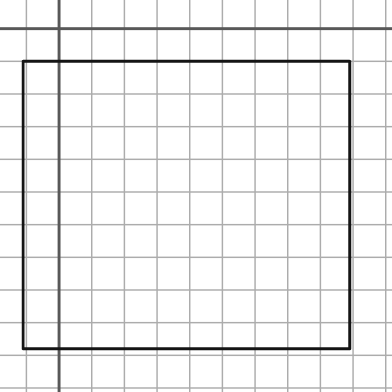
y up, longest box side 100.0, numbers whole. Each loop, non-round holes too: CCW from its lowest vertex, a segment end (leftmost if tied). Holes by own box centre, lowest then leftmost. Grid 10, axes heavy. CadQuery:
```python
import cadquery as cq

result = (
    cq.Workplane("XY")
    .moveTo(-11.0, -98.0)
    .lineTo(89.0, -98.0)
    .lineTo(89.0, -10.0)
    .lineTo(-11.0, -10.0)
    .close()
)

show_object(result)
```